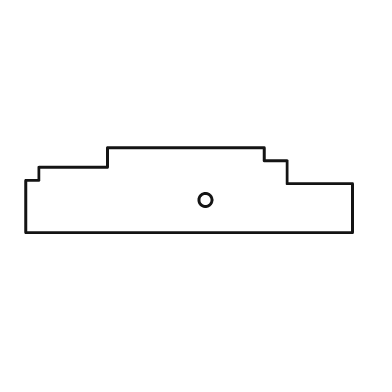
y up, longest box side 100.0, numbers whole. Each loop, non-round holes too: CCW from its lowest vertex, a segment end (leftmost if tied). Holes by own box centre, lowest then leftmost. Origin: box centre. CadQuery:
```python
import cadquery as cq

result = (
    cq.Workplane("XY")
    .moveTo(-50.0, -13.0)
    .lineTo(50.0, -13.0)
    .lineTo(50.0, 2.0)
    .lineTo(30.0, 2.0)
    .lineTo(30.0, 9.0)
    .lineTo(23.0, 9.0)
    .lineTo(23.0, 13.0)
    .lineTo(-25.0, 13.0)
    .lineTo(-25.0, 7.0)
    .lineTo(-46.0, 7.0)
    .lineTo(-46.0, 3.0)
    .lineTo(-50.0, 3.0)
    .close()
    .moveTo(5.0, -3.0)
    .circle(2.0)
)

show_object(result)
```